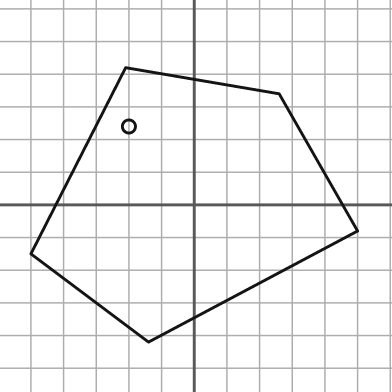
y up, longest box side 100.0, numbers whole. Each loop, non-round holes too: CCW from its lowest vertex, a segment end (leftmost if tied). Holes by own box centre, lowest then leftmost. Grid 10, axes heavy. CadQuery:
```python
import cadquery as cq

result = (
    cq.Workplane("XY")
    .moveTo(-14.0, -42.0)
    .lineTo(50.0, -8.0)
    .lineTo(26.0, 34.0)
    .lineTo(-21.0, 42.0)
    .lineTo(-50.0, -15.0)
    .close()
    .moveTo(-20.0, 24.0)
    .circle(2.0)
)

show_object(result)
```